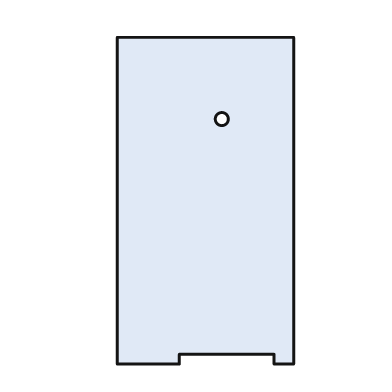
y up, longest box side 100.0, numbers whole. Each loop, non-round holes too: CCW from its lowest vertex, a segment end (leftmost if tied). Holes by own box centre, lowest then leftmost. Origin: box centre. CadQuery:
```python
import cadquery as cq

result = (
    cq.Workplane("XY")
    .moveTo(-27.0, -50.0)
    .lineTo(-8.0, -50.0)
    .lineTo(-8.0, -47.0)
    .lineTo(21.0, -47.0)
    .lineTo(21.0, -50.0)
    .lineTo(27.0, -50.0)
    .lineTo(27.0, 50.0)
    .lineTo(-27.0, 50.0)
    .close()
    .moveTo(5.0, 25.0)
    .circle(2.0)
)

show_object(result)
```